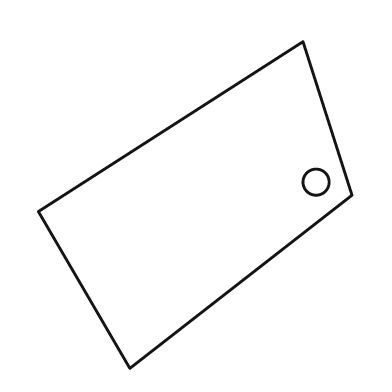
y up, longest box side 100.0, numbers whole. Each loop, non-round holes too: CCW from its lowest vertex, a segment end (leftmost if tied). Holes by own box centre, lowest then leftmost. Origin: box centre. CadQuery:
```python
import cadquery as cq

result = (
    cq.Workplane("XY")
    .moveTo(-20.0, -50.0)
    .lineTo(48.0, 3.0)
    .lineTo(33.0, 50.0)
    .lineTo(-48.0, -2.0)
    .close()
    .moveTo(37.0, 7.0)
    .circle(4.0)
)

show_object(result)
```